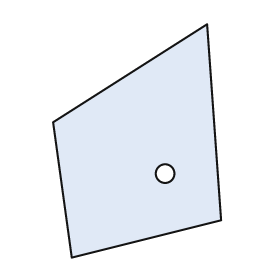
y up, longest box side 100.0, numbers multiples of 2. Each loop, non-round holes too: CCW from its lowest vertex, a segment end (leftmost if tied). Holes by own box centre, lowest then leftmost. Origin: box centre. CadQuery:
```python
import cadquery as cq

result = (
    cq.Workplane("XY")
    .moveTo(-28.0, -50.0)
    .lineTo(36.0, -34.0)
    .lineTo(30.0, 50.0)
    .lineTo(-36.0, 8.0)
    .close()
    .moveTo(12.0, -14.0)
    .circle(4.0)
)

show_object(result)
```